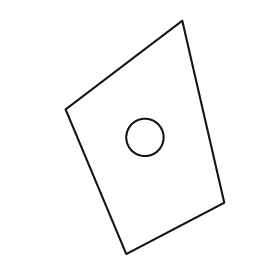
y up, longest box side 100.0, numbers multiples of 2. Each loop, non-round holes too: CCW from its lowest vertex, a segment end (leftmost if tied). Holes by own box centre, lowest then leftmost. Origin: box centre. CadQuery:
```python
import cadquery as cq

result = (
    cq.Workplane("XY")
    .moveTo(-8.0, -50.0)
    .lineTo(34.0, -28.0)
    .lineTo(16.0, 50.0)
    .lineTo(-34.0, 12.0)
    .close()
    .moveTo(0.0, 0.0)
    .circle(8.0)
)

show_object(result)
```